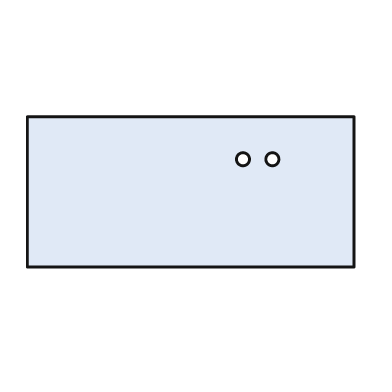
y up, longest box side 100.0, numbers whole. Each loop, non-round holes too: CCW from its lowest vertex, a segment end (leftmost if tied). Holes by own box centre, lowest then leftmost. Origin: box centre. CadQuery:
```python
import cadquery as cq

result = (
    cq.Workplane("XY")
    .moveTo(-50.0, -23.0)
    .lineTo(50.0, -23.0)
    .lineTo(50.0, 23.0)
    .lineTo(-50.0, 23.0)
    .close()
    .moveTo(16.0, 10.0)
    .circle(2.0)
    .moveTo(25.0, 10.0)
    .circle(2.0)
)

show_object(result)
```